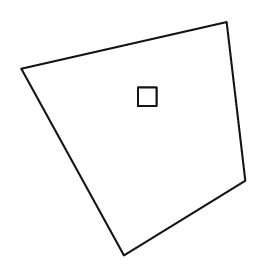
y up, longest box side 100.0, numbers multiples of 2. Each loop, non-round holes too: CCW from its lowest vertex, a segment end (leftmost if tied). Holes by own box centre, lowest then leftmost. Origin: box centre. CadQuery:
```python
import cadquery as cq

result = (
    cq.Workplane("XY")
    .moveTo(-4.0, -50.0)
    .lineTo(48.0, -18.0)
    .lineTo(40.0, 50.0)
    .lineTo(-48.0, 30.0)
    .close()
    .moveTo(2.0, 14.0)
    .lineTo(10.0, 14.0)
    .lineTo(10.0, 22.0)
    .lineTo(2.0, 22.0)
    .close()
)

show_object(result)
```